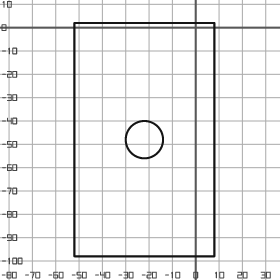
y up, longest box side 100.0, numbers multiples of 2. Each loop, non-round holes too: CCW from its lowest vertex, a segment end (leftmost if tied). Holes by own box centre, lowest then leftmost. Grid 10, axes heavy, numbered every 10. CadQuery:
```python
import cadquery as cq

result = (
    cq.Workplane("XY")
    .moveTo(-52.0, -98.0)
    .lineTo(8.0, -98.0)
    .lineTo(8.0, 2.0)
    .lineTo(-52.0, 2.0)
    .close()
    .moveTo(-22.0, -48.0)
    .circle(8.0)
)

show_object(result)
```